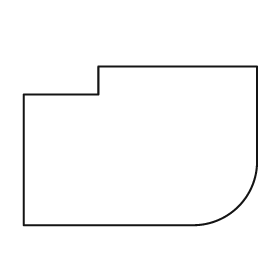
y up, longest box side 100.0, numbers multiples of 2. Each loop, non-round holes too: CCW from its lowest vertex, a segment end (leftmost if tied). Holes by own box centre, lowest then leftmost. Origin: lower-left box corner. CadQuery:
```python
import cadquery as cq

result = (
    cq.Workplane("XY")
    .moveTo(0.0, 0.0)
    .lineTo(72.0, 0.0)
    .threePointArc((92.0, 8.0), (100.0, 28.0))
    .lineTo(100.0, 68.0)
    .lineTo(32.0, 68.0)
    .lineTo(32.0, 56.0)
    .lineTo(0.0, 56.0)
    .close()
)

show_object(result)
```